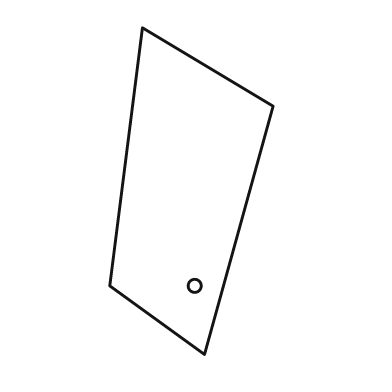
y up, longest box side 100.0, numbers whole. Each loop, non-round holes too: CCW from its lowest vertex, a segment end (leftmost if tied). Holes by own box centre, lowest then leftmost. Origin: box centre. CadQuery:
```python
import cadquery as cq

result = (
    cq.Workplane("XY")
    .moveTo(4.0, -50.0)
    .lineTo(25.0, 26.0)
    .lineTo(-15.0, 50.0)
    .lineTo(-25.0, -29.0)
    .close()
    .moveTo(1.0, -29.0)
    .circle(2.0)
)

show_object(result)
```